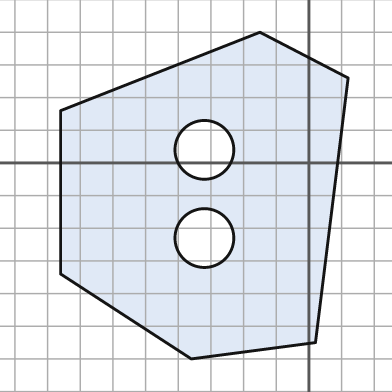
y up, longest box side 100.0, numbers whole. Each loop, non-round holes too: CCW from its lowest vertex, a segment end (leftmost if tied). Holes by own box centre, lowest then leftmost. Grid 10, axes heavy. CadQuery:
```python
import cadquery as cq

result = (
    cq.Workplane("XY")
    .moveTo(-36.0, -60.0)
    .lineTo(2.0, -55.0)
    .lineTo(12.0, 26.0)
    .lineTo(-15.0, 40.0)
    .lineTo(-76.0, 16.0)
    .lineTo(-76.0, -34.0)
    .close()
    .moveTo(-32.0, -23.0)
    .circle(9.0)
    .moveTo(-32.0, 4.0)
    .circle(9.0)
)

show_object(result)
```